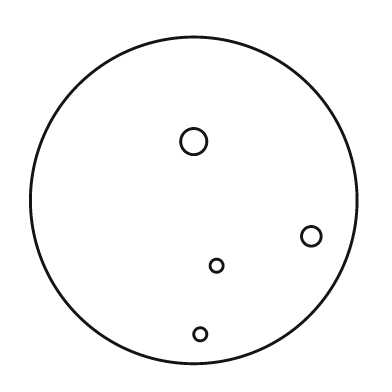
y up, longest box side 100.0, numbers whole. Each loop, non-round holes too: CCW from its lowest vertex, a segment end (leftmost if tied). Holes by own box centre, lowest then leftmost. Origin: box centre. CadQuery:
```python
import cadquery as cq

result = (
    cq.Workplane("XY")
    .moveTo(0.0, 0.0)
    .circle(50.0)
    .moveTo(2.0, -41.0)
    .circle(2.0)
    .moveTo(7.0, -20.0)
    .circle(2.0)
    .moveTo(36.0, -11.0)
    .circle(3.0)
    .moveTo(0.0, 18.0)
    .circle(4.0)
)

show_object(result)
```